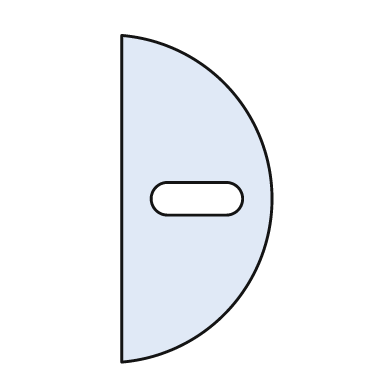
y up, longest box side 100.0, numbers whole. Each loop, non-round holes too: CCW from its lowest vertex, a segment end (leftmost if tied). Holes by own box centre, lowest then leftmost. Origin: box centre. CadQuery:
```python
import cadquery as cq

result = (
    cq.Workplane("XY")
    .moveTo(-23.0, -50.0)
    .threePointArc((23.0, 0.0), (-23.0, 50.0))
    .close()
    .moveTo(-9.0, -5.0)
    .lineTo(9.0, -5.0)
    .threePointArc((14.0, 0.0), (9.0, 5.0))
    .lineTo(-9.0, 5.0)
    .threePointArc((-14.0, 0.0), (-9.0, -5.0))
    .close()
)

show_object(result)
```